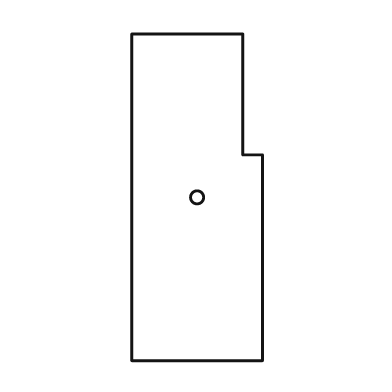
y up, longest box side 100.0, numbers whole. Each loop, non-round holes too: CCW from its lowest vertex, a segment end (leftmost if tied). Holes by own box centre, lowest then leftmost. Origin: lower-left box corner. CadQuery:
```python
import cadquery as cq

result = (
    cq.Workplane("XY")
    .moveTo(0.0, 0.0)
    .lineTo(40.0, 0.0)
    .lineTo(40.0, 63.0)
    .lineTo(34.0, 63.0)
    .lineTo(34.0, 100.0)
    .lineTo(0.0, 100.0)
    .close()
    .moveTo(20.0, 50.0)
    .circle(2.0)
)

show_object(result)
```